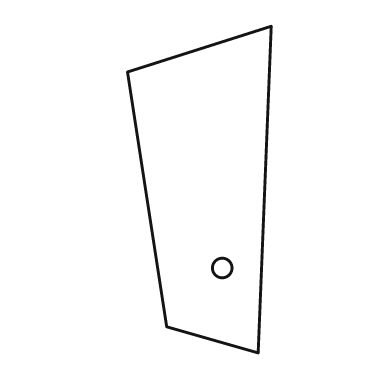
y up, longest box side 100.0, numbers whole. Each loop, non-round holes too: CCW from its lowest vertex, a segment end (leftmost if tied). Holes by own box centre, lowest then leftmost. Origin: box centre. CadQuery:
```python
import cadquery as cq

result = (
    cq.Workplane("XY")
    .moveTo(18.0, -50.0)
    .lineTo(22.0, 50.0)
    .lineTo(-22.0, 36.0)
    .lineTo(-10.0, -42.0)
    .close()
    .moveTo(7.0, -24.0)
    .circle(3.0)
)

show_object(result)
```